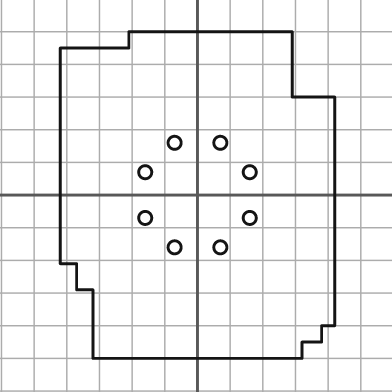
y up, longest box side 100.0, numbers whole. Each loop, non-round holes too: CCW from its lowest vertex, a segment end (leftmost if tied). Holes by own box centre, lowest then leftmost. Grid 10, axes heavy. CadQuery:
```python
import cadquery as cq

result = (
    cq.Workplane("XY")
    .moveTo(-32.0, -50.0)
    .lineTo(32.0, -50.0)
    .lineTo(32.0, -45.0)
    .lineTo(38.0, -45.0)
    .lineTo(38.0, -40.0)
    .lineTo(42.0, -40.0)
    .lineTo(42.0, 30.0)
    .lineTo(29.0, 30.0)
    .lineTo(29.0, 50.0)
    .lineTo(-21.0, 50.0)
    .lineTo(-21.0, 45.0)
    .lineTo(-42.0, 45.0)
    .lineTo(-42.0, -21.0)
    .lineTo(-37.0, -21.0)
    .lineTo(-37.0, -29.0)
    .lineTo(-32.0, -29.0)
    .close()
    .moveTo(-7.0, -16.0)
    .circle(2.0)
    .moveTo(7.0, -16.0)
    .circle(2.0)
    .moveTo(-16.0, -7.0)
    .circle(2.0)
    .moveTo(16.0, -7.0)
    .circle(2.0)
    .moveTo(-16.0, 7.0)
    .circle(2.0)
    .moveTo(16.0, 7.0)
    .circle(2.0)
    .moveTo(-7.0, 16.0)
    .circle(2.0)
    .moveTo(7.0, 16.0)
    .circle(2.0)
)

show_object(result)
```